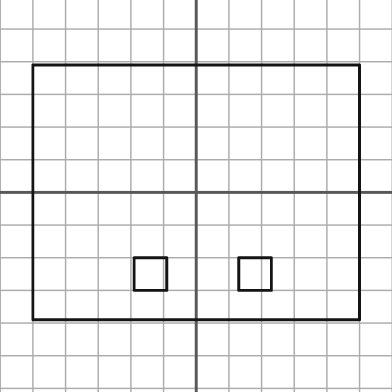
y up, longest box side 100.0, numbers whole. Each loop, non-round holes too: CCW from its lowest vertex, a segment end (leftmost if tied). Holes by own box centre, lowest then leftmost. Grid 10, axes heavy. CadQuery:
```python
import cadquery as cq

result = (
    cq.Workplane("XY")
    .moveTo(-50.0, -39.0)
    .lineTo(50.0, -39.0)
    .lineTo(50.0, 39.0)
    .lineTo(-50.0, 39.0)
    .close()
    .moveTo(-19.0, -30.0)
    .lineTo(-9.0, -30.0)
    .lineTo(-9.0, -20.0)
    .lineTo(-19.0, -20.0)
    .close()
    .moveTo(13.0, -30.0)
    .lineTo(23.0, -30.0)
    .lineTo(23.0, -20.0)
    .lineTo(13.0, -20.0)
    .close()
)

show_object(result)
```